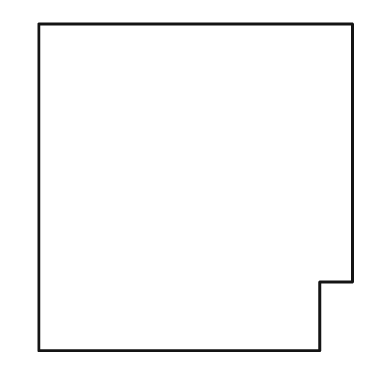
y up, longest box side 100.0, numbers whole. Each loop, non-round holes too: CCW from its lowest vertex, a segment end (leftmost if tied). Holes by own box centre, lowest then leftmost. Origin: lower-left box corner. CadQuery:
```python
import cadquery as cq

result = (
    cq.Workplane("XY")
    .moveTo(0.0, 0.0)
    .lineTo(86.0, 0.0)
    .lineTo(86.0, 21.0)
    .lineTo(96.0, 21.0)
    .lineTo(96.0, 100.0)
    .lineTo(0.0, 100.0)
    .close()
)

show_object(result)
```